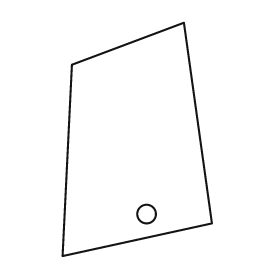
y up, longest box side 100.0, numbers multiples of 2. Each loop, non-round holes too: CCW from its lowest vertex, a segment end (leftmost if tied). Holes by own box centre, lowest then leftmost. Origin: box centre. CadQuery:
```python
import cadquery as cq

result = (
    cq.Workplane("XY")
    .moveTo(-32.0, -50.0)
    .lineTo(32.0, -36.0)
    .lineTo(20.0, 50.0)
    .lineTo(-28.0, 32.0)
    .close()
    .moveTo(4.0, -32.0)
    .circle(4.0)
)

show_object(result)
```